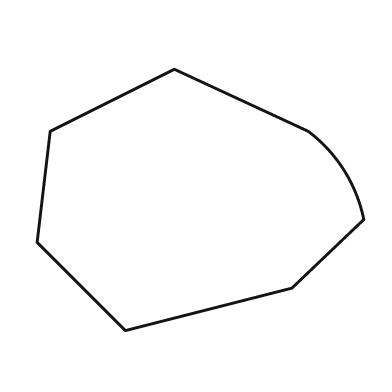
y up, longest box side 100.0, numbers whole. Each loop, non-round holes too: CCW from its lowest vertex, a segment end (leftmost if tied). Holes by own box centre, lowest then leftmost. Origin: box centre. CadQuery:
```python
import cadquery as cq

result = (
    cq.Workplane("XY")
    .moveTo(-23.0, -40.0)
    .lineTo(28.0, -27.0)
    .lineTo(50.0, -6.0)
    .threePointArc((44.0, 9.0), (33.0, 21.0))
    .lineTo(-8.0, 40.0)
    .lineTo(-46.0, 21.0)
    .lineTo(-50.0, -13.0)
    .close()
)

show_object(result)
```